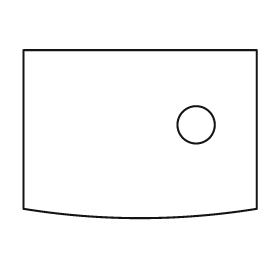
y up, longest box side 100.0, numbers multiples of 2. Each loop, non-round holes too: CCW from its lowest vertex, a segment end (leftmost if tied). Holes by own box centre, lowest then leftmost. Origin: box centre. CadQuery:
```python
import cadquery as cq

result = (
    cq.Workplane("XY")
    .moveTo(-50.0, -32.0)
    .threePointArc((0.0, -36.0), (50.0, -32.0))
    .lineTo(50.0, 36.0)
    .lineTo(-50.0, 36.0)
    .close()
    .moveTo(24.0, 4.0)
    .circle(8.0)
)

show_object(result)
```